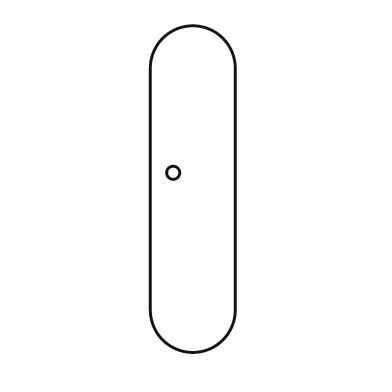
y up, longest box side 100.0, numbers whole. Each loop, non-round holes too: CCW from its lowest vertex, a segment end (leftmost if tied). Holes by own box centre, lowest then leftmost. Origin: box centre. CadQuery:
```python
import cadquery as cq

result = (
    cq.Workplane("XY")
    .moveTo(-13.0, -37.0)
    .threePointArc((0.0, -50.0), (13.0, -37.0))
    .lineTo(13.0, 37.0)
    .threePointArc((0.0, 50.0), (-13.0, 37.0))
    .close()
    .moveTo(-6.0, 5.0)
    .circle(2.0)
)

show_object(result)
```